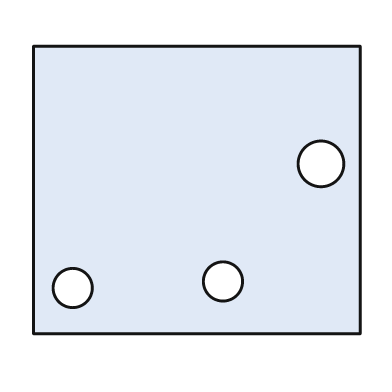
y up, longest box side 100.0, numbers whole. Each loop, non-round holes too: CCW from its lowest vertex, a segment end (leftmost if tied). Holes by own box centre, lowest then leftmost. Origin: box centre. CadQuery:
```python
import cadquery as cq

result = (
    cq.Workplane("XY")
    .moveTo(-50.0, -44.0)
    .lineTo(50.0, -44.0)
    .lineTo(50.0, 44.0)
    .lineTo(-50.0, 44.0)
    .close()
    .moveTo(-38.0, -30.0)
    .circle(6.0)
    .moveTo(8.0, -28.0)
    .circle(6.0)
    .moveTo(38.0, 8.0)
    .circle(7.0)
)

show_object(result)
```